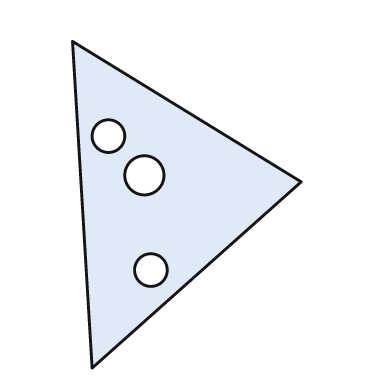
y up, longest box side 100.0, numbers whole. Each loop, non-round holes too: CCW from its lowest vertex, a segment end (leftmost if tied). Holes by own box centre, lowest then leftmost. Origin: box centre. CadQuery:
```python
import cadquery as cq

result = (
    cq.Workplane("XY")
    .moveTo(-29.0, -50.0)
    .lineTo(35.0, 7.0)
    .lineTo(-35.0, 50.0)
    .close()
    .moveTo(-11.0, -20.0)
    .circle(5.0)
    .moveTo(-13.0, 9.0)
    .circle(6.0)
    .moveTo(-24.0, 21.0)
    .circle(5.0)
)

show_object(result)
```